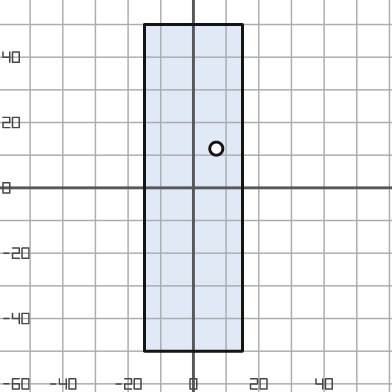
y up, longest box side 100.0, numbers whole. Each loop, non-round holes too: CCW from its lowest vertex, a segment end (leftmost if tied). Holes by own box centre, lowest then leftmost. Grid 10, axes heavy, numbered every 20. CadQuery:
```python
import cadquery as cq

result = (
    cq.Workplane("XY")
    .moveTo(-15.0, -50.0)
    .lineTo(15.0, -50.0)
    .lineTo(15.0, 50.0)
    .lineTo(-15.0, 50.0)
    .close()
    .moveTo(7.0, 12.0)
    .circle(2.0)
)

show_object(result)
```